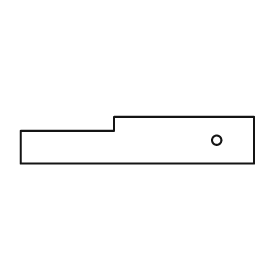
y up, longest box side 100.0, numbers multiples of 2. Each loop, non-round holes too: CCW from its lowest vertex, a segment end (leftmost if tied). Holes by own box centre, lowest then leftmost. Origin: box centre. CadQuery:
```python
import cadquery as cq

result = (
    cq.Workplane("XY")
    .moveTo(-50.0, -10.0)
    .lineTo(50.0, -10.0)
    .lineTo(50.0, 10.0)
    .lineTo(-10.0, 10.0)
    .lineTo(-10.0, 4.0)
    .lineTo(-50.0, 4.0)
    .close()
    .moveTo(34.0, 0.0)
    .circle(2.0)
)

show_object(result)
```